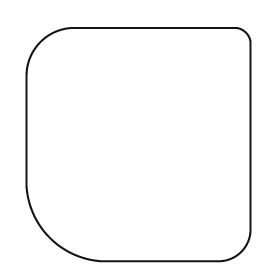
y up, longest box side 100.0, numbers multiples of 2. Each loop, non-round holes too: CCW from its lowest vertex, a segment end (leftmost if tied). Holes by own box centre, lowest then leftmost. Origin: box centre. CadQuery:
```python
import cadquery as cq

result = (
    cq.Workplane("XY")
    .moveTo(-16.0, -50.0)
    .lineTo(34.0, -50.0)
    .threePointArc((44.0, -46.0), (48.0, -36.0))
    .lineTo(48.0, 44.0)
    .threePointArc((46.0, 48.0), (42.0, 50.0))
    .lineTo(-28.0, 50.0)
    .threePointArc((-42.0, 44.0), (-48.0, 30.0))
    .lineTo(-48.0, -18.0)
    .threePointArc((-38.0, -40.0), (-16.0, -50.0))
    .close()
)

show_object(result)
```